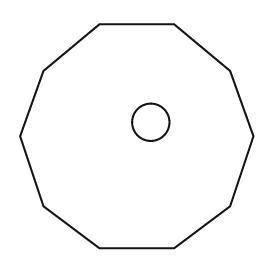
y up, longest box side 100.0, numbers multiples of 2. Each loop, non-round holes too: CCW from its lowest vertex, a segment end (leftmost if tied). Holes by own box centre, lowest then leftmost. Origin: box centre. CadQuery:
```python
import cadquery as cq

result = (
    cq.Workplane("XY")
    .moveTo(-16.0, -48.0)
    .lineTo(16.0, -48.0)
    .lineTo(40.0, -30.0)
    .lineTo(50.0, 0.0)
    .lineTo(40.0, 28.0)
    .lineTo(16.0, 48.0)
    .lineTo(-16.0, 48.0)
    .lineTo(-40.0, 28.0)
    .lineTo(-50.0, 0.0)
    .lineTo(-40.0, -30.0)
    .close()
    .moveTo(6.0, 6.0)
    .circle(8.0)
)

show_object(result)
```